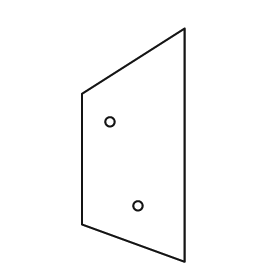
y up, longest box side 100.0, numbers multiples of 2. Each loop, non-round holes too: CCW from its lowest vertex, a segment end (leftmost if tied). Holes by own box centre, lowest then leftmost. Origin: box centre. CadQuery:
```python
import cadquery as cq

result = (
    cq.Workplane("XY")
    .moveTo(22.0, -50.0)
    .lineTo(22.0, 50.0)
    .lineTo(-22.0, 22.0)
    .lineTo(-22.0, -34.0)
    .close()
    .moveTo(2.0, -26.0)
    .circle(2.0)
    .moveTo(-10.0, 10.0)
    .circle(2.0)
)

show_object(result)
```